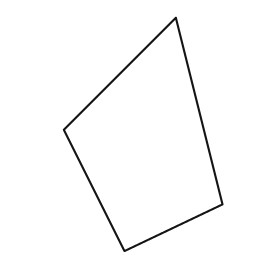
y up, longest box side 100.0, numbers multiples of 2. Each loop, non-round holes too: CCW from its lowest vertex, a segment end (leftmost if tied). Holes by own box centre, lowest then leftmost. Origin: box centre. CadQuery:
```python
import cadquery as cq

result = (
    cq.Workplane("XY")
    .moveTo(-8.0, -50.0)
    .lineTo(34.0, -30.0)
    .lineTo(14.0, 50.0)
    .lineTo(-34.0, 2.0)
    .close()
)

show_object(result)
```